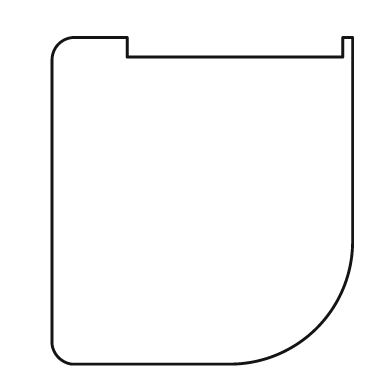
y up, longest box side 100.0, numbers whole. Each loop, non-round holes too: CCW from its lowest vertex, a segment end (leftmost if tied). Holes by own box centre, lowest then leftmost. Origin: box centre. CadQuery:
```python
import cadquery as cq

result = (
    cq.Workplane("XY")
    .moveTo(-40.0, -50.0)
    .lineTo(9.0, -50.0)
    .threePointArc((35.0, -39.0), (46.0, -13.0))
    .lineTo(46.0, 50.0)
    .lineTo(43.0, 50.0)
    .lineTo(43.0, 44.0)
    .lineTo(-23.0, 44.0)
    .lineTo(-23.0, 50.0)
    .lineTo(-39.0, 50.0)
    .threePointArc((-44.0, 48.0), (-46.0, 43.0))
    .lineTo(-46.0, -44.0)
    .threePointArc((-44.0, -48.0), (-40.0, -50.0))
    .close()
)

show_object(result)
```